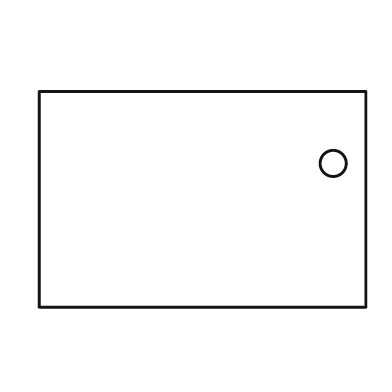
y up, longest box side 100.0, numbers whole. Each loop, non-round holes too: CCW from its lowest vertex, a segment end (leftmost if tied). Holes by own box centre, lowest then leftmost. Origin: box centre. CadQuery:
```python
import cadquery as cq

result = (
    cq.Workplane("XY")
    .moveTo(-50.0, -33.0)
    .lineTo(50.0, -33.0)
    .lineTo(50.0, 33.0)
    .lineTo(-50.0, 33.0)
    .close()
    .moveTo(40.0, 11.0)
    .circle(4.0)
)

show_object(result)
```